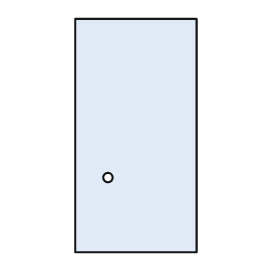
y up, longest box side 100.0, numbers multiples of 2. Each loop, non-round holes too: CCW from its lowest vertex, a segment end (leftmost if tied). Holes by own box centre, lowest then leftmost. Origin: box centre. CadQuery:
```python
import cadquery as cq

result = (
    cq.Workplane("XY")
    .moveTo(-26.0, -50.0)
    .lineTo(26.0, -50.0)
    .lineTo(26.0, 50.0)
    .lineTo(-26.0, 50.0)
    .close()
    .moveTo(-12.0, -18.0)
    .circle(2.0)
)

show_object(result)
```